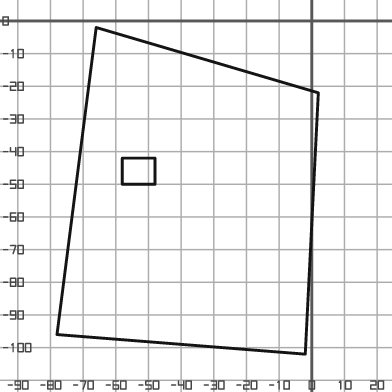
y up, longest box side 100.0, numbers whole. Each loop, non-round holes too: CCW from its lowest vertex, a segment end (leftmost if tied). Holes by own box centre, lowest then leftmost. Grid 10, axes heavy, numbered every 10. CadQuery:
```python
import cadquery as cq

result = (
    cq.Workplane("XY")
    .moveTo(-2.0, -102.0)
    .lineTo(2.0, -22.0)
    .lineTo(-66.0, -2.0)
    .lineTo(-78.0, -96.0)
    .close()
    .moveTo(-58.0, -50.0)
    .lineTo(-48.0, -50.0)
    .lineTo(-48.0, -42.0)
    .lineTo(-58.0, -42.0)
    .close()
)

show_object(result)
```